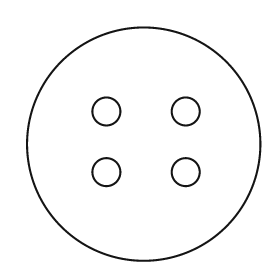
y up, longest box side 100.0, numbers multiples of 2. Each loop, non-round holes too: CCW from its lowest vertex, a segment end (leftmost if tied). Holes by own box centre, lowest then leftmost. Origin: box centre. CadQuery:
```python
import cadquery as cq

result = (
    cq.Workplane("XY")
    .moveTo(0.0, 0.0)
    .circle(50.0)
    .moveTo(-16.0, -12.0)
    .circle(6.0)
    .moveTo(18.0, -12.0)
    .circle(6.0)
    .moveTo(-16.0, 14.0)
    .circle(6.0)
    .moveTo(18.0, 14.0)
    .circle(6.0)
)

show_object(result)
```